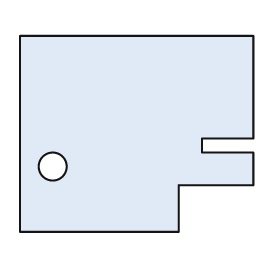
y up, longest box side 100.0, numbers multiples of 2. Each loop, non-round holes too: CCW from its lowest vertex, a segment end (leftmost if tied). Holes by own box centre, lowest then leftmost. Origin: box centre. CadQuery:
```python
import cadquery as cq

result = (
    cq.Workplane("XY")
    .moveTo(-50.0, -42.0)
    .lineTo(18.0, -42.0)
    .lineTo(18.0, -22.0)
    .lineTo(50.0, -22.0)
    .lineTo(50.0, -8.0)
    .lineTo(28.0, -8.0)
    .lineTo(28.0, -2.0)
    .lineTo(50.0, -2.0)
    .lineTo(50.0, 42.0)
    .lineTo(-50.0, 42.0)
    .close()
    .moveTo(-36.0, -14.0)
    .circle(6.0)
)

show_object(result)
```